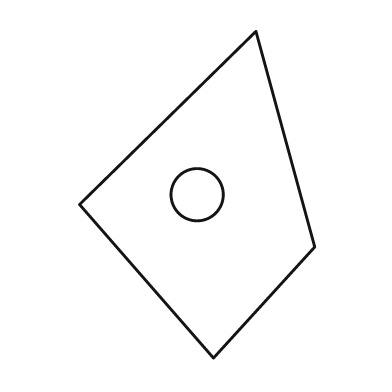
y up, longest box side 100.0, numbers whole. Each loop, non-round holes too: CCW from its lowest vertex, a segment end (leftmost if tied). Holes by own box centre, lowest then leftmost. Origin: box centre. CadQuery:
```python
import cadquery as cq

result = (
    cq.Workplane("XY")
    .moveTo(5.0, -50.0)
    .lineTo(36.0, -16.0)
    .lineTo(18.0, 50.0)
    .lineTo(-36.0, -3.0)
    .close()
    .moveTo(0.0, 0.0)
    .circle(8.0)
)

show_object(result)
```